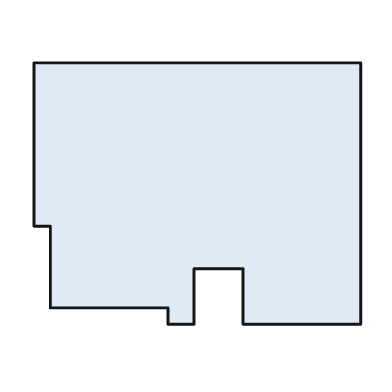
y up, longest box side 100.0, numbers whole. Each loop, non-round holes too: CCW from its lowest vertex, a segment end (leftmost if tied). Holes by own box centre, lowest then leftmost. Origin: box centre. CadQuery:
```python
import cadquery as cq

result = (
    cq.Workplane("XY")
    .moveTo(-9.0, -40.0)
    .lineTo(-1.0, -40.0)
    .lineTo(-1.0, -23.0)
    .lineTo(14.0, -23.0)
    .lineTo(14.0, -40.0)
    .lineTo(50.0, -40.0)
    .lineTo(50.0, 40.0)
    .lineTo(-50.0, 40.0)
    .lineTo(-50.0, -10.0)
    .lineTo(-45.0, -10.0)
    .lineTo(-45.0, -35.0)
    .lineTo(-9.0, -35.0)
    .close()
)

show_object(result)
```